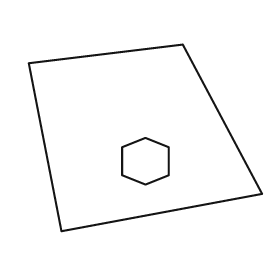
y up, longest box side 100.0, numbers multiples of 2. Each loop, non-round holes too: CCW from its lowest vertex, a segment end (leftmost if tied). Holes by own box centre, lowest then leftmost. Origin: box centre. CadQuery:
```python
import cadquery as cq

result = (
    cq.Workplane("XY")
    .moveTo(-36.0, -40.0)
    .lineTo(50.0, -24.0)
    .lineTo(16.0, 40.0)
    .lineTo(-50.0, 32.0)
    .close()
    .moveTo(0.0, -20.0)
    .lineTo(10.0, -16.0)
    .lineTo(10.0, -4.0)
    .lineTo(0.0, 0.0)
    .lineTo(-10.0, -4.0)
    .lineTo(-10.0, -16.0)
    .close()
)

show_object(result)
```